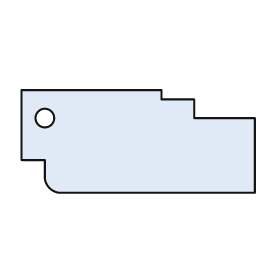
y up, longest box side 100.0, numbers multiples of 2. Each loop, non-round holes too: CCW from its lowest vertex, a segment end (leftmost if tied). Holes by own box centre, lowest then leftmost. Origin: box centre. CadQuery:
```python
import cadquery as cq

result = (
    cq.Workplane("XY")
    .moveTo(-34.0, -22.0)
    .lineTo(50.0, -22.0)
    .lineTo(50.0, 10.0)
    .lineTo(24.0, 10.0)
    .lineTo(24.0, 18.0)
    .lineTo(10.0, 18.0)
    .lineTo(10.0, 22.0)
    .lineTo(-50.0, 22.0)
    .lineTo(-50.0, -8.0)
    .lineTo(-40.0, -8.0)
    .lineTo(-40.0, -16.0)
    .threePointArc((-38.0, -20.0), (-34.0, -22.0))
    .close()
    .moveTo(-40.0, 10.0)
    .circle(4.0)
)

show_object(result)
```